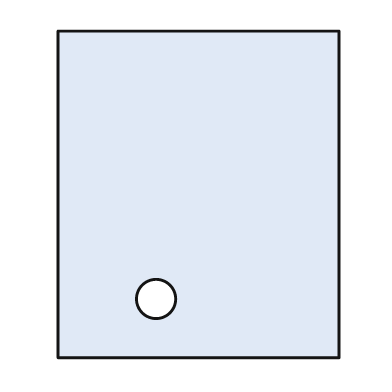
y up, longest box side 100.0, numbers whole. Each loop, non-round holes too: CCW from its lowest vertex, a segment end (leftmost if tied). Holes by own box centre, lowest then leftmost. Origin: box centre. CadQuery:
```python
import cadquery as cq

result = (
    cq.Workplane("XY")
    .moveTo(-43.0, -50.0)
    .lineTo(43.0, -50.0)
    .lineTo(43.0, 50.0)
    .lineTo(-43.0, 50.0)
    .close()
    .moveTo(-13.0, -32.0)
    .circle(6.0)
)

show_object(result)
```